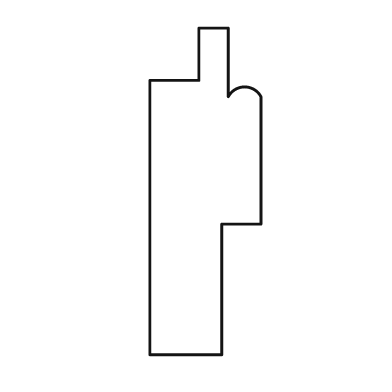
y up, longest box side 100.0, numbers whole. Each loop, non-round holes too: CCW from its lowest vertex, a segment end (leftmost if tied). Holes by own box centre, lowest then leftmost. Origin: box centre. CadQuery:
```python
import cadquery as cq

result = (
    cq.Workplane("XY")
    .moveTo(-17.0, -50.0)
    .lineTo(5.0, -50.0)
    .lineTo(5.0, -10.0)
    .lineTo(17.0, -10.0)
    .lineTo(17.0, 29.0)
    .threePointArc((12.0, 32.0), (7.0, 29.0))
    .lineTo(7.0, 50.0)
    .lineTo(-2.0, 50.0)
    .lineTo(-2.0, 34.0)
    .lineTo(-17.0, 34.0)
    .close()
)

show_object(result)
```